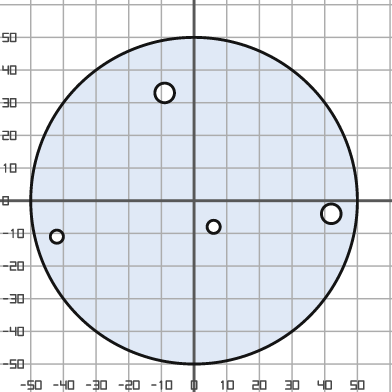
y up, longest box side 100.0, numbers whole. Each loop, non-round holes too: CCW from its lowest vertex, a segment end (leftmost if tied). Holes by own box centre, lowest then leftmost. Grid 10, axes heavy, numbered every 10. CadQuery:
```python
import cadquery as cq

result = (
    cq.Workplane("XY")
    .moveTo(0.0, 0.0)
    .circle(50.0)
    .moveTo(-42.0, -11.0)
    .circle(2.0)
    .moveTo(6.0, -8.0)
    .circle(2.0)
    .moveTo(42.0, -4.0)
    .circle(3.0)
    .moveTo(-9.0, 33.0)
    .circle(3.0)
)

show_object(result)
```